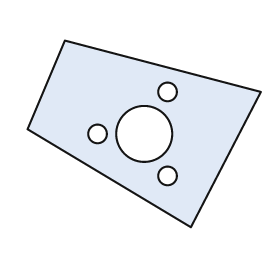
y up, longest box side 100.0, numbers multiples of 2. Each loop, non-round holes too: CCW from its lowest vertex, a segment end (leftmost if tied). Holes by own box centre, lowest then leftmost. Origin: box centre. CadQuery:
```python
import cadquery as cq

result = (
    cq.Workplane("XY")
    .moveTo(20.0, -40.0)
    .lineTo(50.0, 18.0)
    .lineTo(-34.0, 40.0)
    .lineTo(-50.0, 2.0)
    .close()
    .moveTo(10.0, -18.0)
    .circle(4.0)
    .moveTo(-20.0, 0.0)
    .circle(4.0)
    .moveTo(0.0, 0.0)
    .circle(12.0)
    .moveTo(10.0, 18.0)
    .circle(4.0)
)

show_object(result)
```